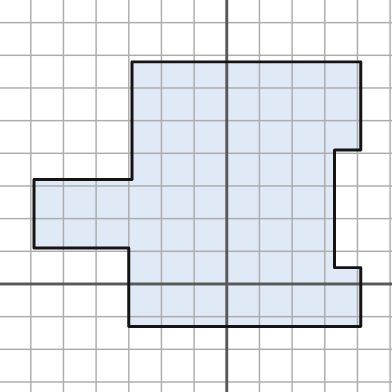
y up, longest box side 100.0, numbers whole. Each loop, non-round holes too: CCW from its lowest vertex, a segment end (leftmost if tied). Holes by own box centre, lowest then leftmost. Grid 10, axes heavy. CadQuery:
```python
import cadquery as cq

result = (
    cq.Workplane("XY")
    .moveTo(-30.0, -13.0)
    .lineTo(41.0, -13.0)
    .lineTo(41.0, 5.0)
    .lineTo(33.0, 5.0)
    .lineTo(33.0, 41.0)
    .lineTo(41.0, 41.0)
    .lineTo(41.0, 68.0)
    .lineTo(-29.0, 68.0)
    .lineTo(-29.0, 32.0)
    .lineTo(-59.0, 32.0)
    .lineTo(-59.0, 11.0)
    .lineTo(-30.0, 11.0)
    .close()
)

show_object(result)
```